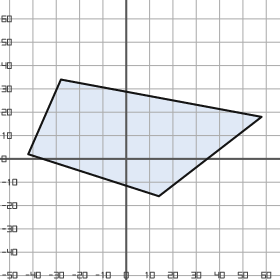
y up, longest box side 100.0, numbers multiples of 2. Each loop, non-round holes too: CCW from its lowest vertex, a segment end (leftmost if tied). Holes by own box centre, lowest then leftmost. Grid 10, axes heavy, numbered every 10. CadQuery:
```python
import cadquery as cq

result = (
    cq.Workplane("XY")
    .moveTo(14.0, -16.0)
    .lineTo(58.0, 18.0)
    .lineTo(-28.0, 34.0)
    .lineTo(-42.0, 2.0)
    .close()
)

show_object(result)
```